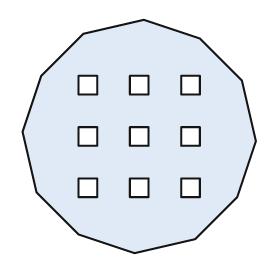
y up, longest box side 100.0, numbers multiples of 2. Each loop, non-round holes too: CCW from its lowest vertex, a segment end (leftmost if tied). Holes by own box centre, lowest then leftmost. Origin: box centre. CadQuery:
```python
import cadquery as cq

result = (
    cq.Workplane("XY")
    .moveTo(-2.0, -50.0)
    .lineTo(24.0, -44.0)
    .lineTo(42.0, -26.0)
    .lineTo(50.0, -2.0)
    .lineTo(44.0, 24.0)
    .lineTo(26.0, 42.0)
    .lineTo(2.0, 50.0)
    .lineTo(-24.0, 44.0)
    .lineTo(-42.0, 26.0)
    .lineTo(-50.0, 2.0)
    .lineTo(-44.0, -24.0)
    .lineTo(-26.0, -42.0)
    .close()
    .moveTo(-26.0, -26.0)
    .lineTo(-18.0, -26.0)
    .lineTo(-18.0, -18.0)
    .lineTo(-26.0, -18.0)
    .close()
    .moveTo(-4.0, -26.0)
    .lineTo(4.0, -26.0)
    .lineTo(4.0, -18.0)
    .lineTo(-4.0, -18.0)
    .close()
    .moveTo(18.0, -26.0)
    .lineTo(26.0, -26.0)
    .lineTo(26.0, -18.0)
    .lineTo(18.0, -18.0)
    .close()
    .moveTo(-26.0, -4.0)
    .lineTo(-18.0, -4.0)
    .lineTo(-18.0, 4.0)
    .lineTo(-26.0, 4.0)
    .close()
    .moveTo(-4.0, -4.0)
    .lineTo(4.0, -4.0)
    .lineTo(4.0, 4.0)
    .lineTo(-4.0, 4.0)
    .close()
    .moveTo(18.0, -4.0)
    .lineTo(26.0, -4.0)
    .lineTo(26.0, 4.0)
    .lineTo(18.0, 4.0)
    .close()
    .moveTo(-26.0, 18.0)
    .lineTo(-18.0, 18.0)
    .lineTo(-18.0, 26.0)
    .lineTo(-26.0, 26.0)
    .close()
    .moveTo(-4.0, 18.0)
    .lineTo(4.0, 18.0)
    .lineTo(4.0, 26.0)
    .lineTo(-4.0, 26.0)
    .close()
    .moveTo(18.0, 18.0)
    .lineTo(26.0, 18.0)
    .lineTo(26.0, 26.0)
    .lineTo(18.0, 26.0)
    .close()
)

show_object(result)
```